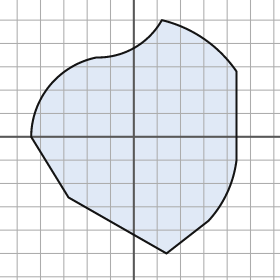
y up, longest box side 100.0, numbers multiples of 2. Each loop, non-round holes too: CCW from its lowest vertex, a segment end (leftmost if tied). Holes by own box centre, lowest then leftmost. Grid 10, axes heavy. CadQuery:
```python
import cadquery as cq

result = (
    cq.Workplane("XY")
    .moveTo(14.0, -50.0)
    .lineTo(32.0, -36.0)
    .threePointArc((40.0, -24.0), (44.0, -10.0))
    .lineTo(44.0, 28.0)
    .threePointArc((30.0, 42.0), (12.0, 50.0))
    .threePointArc((0.0, 38.0), (-16.0, 34.0))
    .threePointArc((-36.0, 22.0), (-44.0, 0.0))
    .lineTo(-28.0, -26.0)
    .close()
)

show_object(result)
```